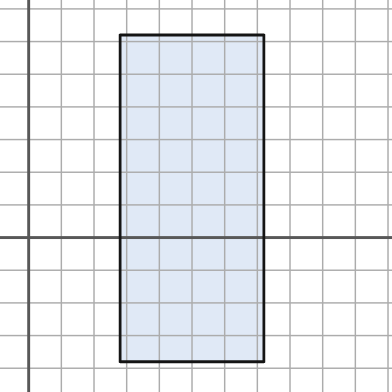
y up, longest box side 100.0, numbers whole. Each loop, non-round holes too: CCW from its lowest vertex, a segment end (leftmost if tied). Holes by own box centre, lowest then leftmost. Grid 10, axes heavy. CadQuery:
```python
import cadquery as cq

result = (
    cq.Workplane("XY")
    .moveTo(28.0, -38.0)
    .lineTo(72.0, -38.0)
    .lineTo(72.0, 62.0)
    .lineTo(28.0, 62.0)
    .close()
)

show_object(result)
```